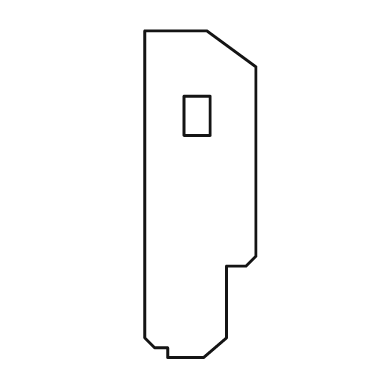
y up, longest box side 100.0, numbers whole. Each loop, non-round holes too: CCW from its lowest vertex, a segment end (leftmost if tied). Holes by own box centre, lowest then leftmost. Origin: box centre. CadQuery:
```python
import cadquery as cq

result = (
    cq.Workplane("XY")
    .moveTo(-10.0, -50.0)
    .lineTo(1.0, -50.0)
    .lineTo(8.0, -44.0)
    .lineTo(8.0, -22.0)
    .lineTo(14.0, -22.0)
    .lineTo(17.0, -19.0)
    .lineTo(17.0, 39.0)
    .lineTo(2.0, 50.0)
    .lineTo(-17.0, 50.0)
    .lineTo(-17.0, -44.0)
    .lineTo(-14.0, -47.0)
    .lineTo(-10.0, -47.0)
    .close()
    .moveTo(-5.0, 18.0)
    .lineTo(3.0, 18.0)
    .lineTo(3.0, 30.0)
    .lineTo(-5.0, 30.0)
    .close()
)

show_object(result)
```